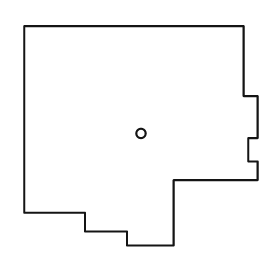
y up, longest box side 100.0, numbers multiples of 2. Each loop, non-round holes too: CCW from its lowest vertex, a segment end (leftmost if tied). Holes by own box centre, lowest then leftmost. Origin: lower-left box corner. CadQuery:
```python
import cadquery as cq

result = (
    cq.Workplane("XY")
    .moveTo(44.0, 0.0)
    .lineTo(64.0, 0.0)
    .lineTo(64.0, 28.0)
    .lineTo(100.0, 28.0)
    .lineTo(100.0, 36.0)
    .lineTo(96.0, 36.0)
    .lineTo(96.0, 46.0)
    .lineTo(100.0, 46.0)
    .lineTo(100.0, 64.0)
    .lineTo(94.0, 64.0)
    .lineTo(94.0, 94.0)
    .lineTo(0.0, 94.0)
    .lineTo(0.0, 14.0)
    .lineTo(26.0, 14.0)
    .lineTo(26.0, 6.0)
    .lineTo(44.0, 6.0)
    .close()
    .moveTo(50.0, 48.0)
    .circle(2.0)
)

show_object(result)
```